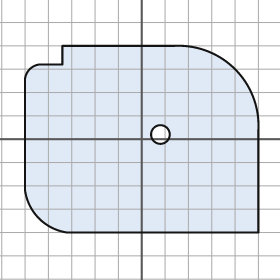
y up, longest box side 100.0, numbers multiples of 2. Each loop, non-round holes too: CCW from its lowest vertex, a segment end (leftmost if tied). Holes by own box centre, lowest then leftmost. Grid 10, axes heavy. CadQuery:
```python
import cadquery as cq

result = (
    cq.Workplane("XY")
    .moveTo(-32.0, -40.0)
    .lineTo(50.0, -40.0)
    .lineTo(50.0, 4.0)
    .threePointArc((40.0, 30.0), (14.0, 40.0))
    .lineTo(-34.0, 40.0)
    .lineTo(-34.0, 32.0)
    .lineTo(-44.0, 32.0)
    .threePointArc((-48.0, 30.0), (-50.0, 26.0))
    .lineTo(-50.0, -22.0)
    .threePointArc((-44.0, -34.0), (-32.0, -40.0))
    .close()
    .moveTo(8.0, 2.0)
    .circle(4.0)
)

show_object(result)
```